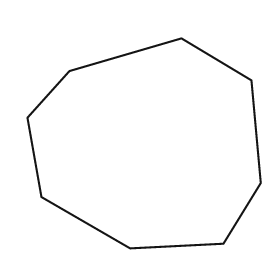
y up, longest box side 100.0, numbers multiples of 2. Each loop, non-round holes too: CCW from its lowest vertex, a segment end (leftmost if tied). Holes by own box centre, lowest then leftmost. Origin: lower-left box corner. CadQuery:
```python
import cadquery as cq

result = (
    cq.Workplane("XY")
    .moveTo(44.0, 0.0)
    .lineTo(84.0, 2.0)
    .lineTo(100.0, 28.0)
    .lineTo(96.0, 72.0)
    .lineTo(66.0, 90.0)
    .lineTo(18.0, 76.0)
    .lineTo(0.0, 56.0)
    .lineTo(6.0, 22.0)
    .close()
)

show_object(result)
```